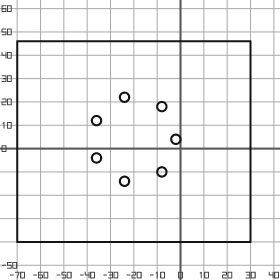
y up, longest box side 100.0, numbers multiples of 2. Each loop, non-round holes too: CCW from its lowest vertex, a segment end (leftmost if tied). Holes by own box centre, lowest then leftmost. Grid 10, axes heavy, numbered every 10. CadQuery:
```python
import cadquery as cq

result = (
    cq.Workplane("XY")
    .moveTo(-70.0, -40.0)
    .lineTo(30.0, -40.0)
    .lineTo(30.0, 46.0)
    .lineTo(-70.0, 46.0)
    .close()
    .moveTo(-24.0, -14.0)
    .circle(2.0)
    .moveTo(-8.0, -10.0)
    .circle(2.0)
    .moveTo(-36.0, -4.0)
    .circle(2.0)
    .moveTo(-2.0, 4.0)
    .circle(2.0)
    .moveTo(-36.0, 12.0)
    .circle(2.0)
    .moveTo(-8.0, 18.0)
    .circle(2.0)
    .moveTo(-24.0, 22.0)
    .circle(2.0)
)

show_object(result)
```